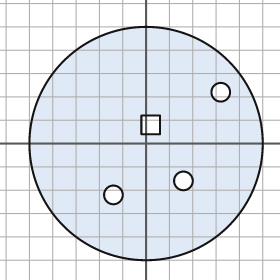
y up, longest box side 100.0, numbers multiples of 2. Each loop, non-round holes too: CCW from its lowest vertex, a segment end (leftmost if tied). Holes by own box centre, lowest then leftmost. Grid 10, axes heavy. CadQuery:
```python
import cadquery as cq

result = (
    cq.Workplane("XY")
    .moveTo(0.0, 0.0)
    .circle(50.0)
    .moveTo(-14.0, -22.0)
    .circle(4.0)
    .moveTo(16.0, -16.0)
    .circle(4.0)
    .moveTo(-2.0, 4.0)
    .lineTo(6.0, 4.0)
    .lineTo(6.0, 12.0)
    .lineTo(-2.0, 12.0)
    .close()
    .moveTo(32.0, 22.0)
    .circle(4.0)
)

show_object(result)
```